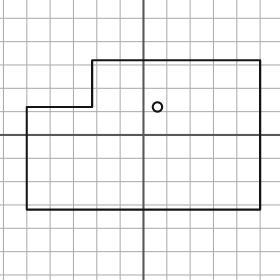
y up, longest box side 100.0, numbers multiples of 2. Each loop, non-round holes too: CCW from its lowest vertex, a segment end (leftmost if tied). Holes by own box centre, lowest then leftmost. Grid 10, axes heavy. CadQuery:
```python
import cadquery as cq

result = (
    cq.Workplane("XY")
    .moveTo(-50.0, -32.0)
    .lineTo(50.0, -32.0)
    .lineTo(50.0, 32.0)
    .lineTo(-22.0, 32.0)
    .lineTo(-22.0, 12.0)
    .lineTo(-50.0, 12.0)
    .close()
    .moveTo(6.0, 12.0)
    .circle(2.0)
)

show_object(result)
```